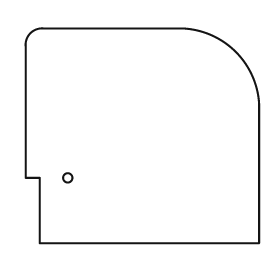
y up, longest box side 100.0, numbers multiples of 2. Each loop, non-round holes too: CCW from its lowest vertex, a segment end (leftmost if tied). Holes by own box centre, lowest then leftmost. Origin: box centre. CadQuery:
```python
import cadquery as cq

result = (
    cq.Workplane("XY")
    .moveTo(-44.0, -46.0)
    .lineTo(50.0, -46.0)
    .lineTo(50.0, 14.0)
    .threePointArc((40.0, 36.0), (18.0, 46.0))
    .lineTo(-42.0, 46.0)
    .threePointArc((-48.0, 44.0), (-50.0, 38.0))
    .lineTo(-50.0, -18.0)
    .lineTo(-44.0, -18.0)
    .close()
    .moveTo(-32.0, -18.0)
    .circle(2.0)
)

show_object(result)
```